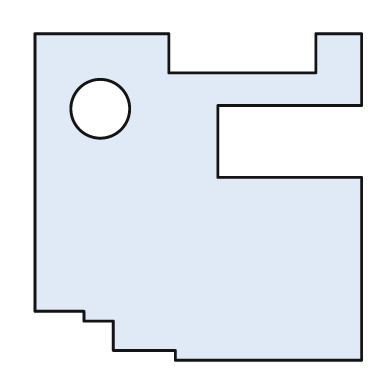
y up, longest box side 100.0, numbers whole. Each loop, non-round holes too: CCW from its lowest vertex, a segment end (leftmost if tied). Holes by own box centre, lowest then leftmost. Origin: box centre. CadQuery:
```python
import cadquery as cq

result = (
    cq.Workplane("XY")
    .moveTo(-7.0, -50.0)
    .lineTo(50.0, -50.0)
    .lineTo(50.0, 6.0)
    .lineTo(6.0, 6.0)
    .lineTo(6.0, 28.0)
    .lineTo(50.0, 28.0)
    .lineTo(50.0, 50.0)
    .lineTo(36.0, 50.0)
    .lineTo(36.0, 38.0)
    .lineTo(-9.0, 38.0)
    .lineTo(-9.0, 50.0)
    .lineTo(-50.0, 50.0)
    .lineTo(-50.0, -35.0)
    .lineTo(-35.0, -35.0)
    .lineTo(-35.0, -38.0)
    .lineTo(-26.0, -38.0)
    .lineTo(-26.0, -47.0)
    .lineTo(-7.0, -47.0)
    .close()
    .moveTo(-30.0, 27.0)
    .circle(9.0)
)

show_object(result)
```